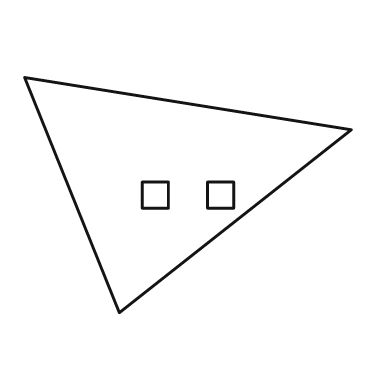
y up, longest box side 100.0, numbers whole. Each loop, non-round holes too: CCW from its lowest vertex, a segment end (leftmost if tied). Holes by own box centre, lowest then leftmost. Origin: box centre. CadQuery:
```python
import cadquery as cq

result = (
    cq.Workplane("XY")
    .moveTo(-21.0, -36.0)
    .lineTo(50.0, 20.0)
    .lineTo(-50.0, 36.0)
    .close()
    .moveTo(-14.0, -4.0)
    .lineTo(-6.0, -4.0)
    .lineTo(-6.0, 4.0)
    .lineTo(-14.0, 4.0)
    .close()
    .moveTo(6.0, -4.0)
    .lineTo(14.0, -4.0)
    .lineTo(14.0, 4.0)
    .lineTo(6.0, 4.0)
    .close()
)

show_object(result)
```